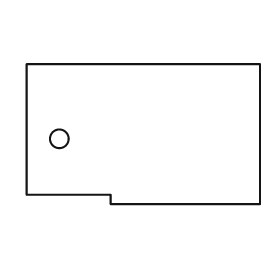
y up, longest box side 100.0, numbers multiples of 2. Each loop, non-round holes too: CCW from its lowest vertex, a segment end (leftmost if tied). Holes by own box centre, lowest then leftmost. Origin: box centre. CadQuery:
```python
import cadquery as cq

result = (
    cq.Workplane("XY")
    .moveTo(-14.0, -30.0)
    .lineTo(50.0, -30.0)
    .lineTo(50.0, 30.0)
    .lineTo(-50.0, 30.0)
    .lineTo(-50.0, -26.0)
    .lineTo(-14.0, -26.0)
    .close()
    .moveTo(-36.0, -2.0)
    .circle(4.0)
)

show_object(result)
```